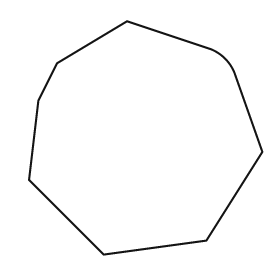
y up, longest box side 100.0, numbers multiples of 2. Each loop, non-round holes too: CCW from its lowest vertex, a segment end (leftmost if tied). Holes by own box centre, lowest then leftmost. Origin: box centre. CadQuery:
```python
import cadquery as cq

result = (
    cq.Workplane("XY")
    .moveTo(-18.0, -50.0)
    .lineTo(26.0, -44.0)
    .lineTo(50.0, -6.0)
    .lineTo(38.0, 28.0)
    .threePointArc((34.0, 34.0), (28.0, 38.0))
    .lineTo(-8.0, 50.0)
    .lineTo(-38.0, 32.0)
    .lineTo(-46.0, 16.0)
    .lineTo(-50.0, -18.0)
    .close()
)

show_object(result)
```